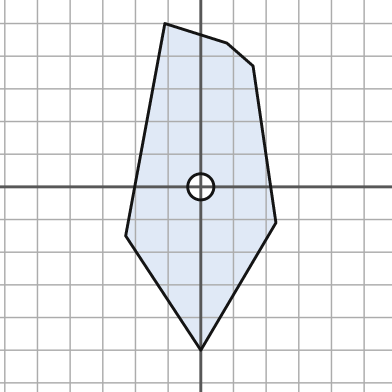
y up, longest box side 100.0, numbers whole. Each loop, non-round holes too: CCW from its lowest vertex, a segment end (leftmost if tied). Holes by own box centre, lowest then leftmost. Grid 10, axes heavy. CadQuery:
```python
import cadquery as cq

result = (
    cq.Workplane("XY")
    .moveTo(0.0, -50.0)
    .lineTo(23.0, -11.0)
    .lineTo(16.0, 37.0)
    .lineTo(8.0, 44.0)
    .lineTo(-11.0, 50.0)
    .lineTo(-23.0, -15.0)
    .close()
    .moveTo(0.0, 0.0)
    .circle(4.0)
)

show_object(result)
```